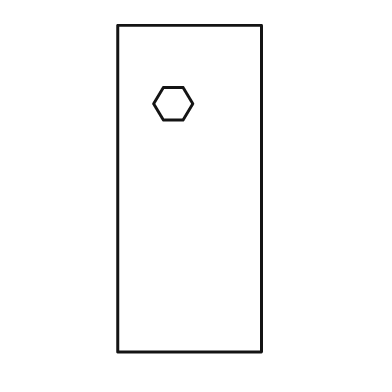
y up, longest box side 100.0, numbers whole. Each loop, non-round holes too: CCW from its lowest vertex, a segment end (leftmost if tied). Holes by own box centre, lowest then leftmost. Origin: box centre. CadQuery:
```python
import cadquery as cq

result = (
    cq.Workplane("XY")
    .moveTo(-22.0, -50.0)
    .lineTo(22.0, -50.0)
    .lineTo(22.0, 50.0)
    .lineTo(-22.0, 50.0)
    .close()
    .moveTo(-8.0, 21.0)
    .lineTo(-2.0, 21.0)
    .lineTo(1.0, 26.0)
    .lineTo(-2.0, 31.0)
    .lineTo(-8.0, 31.0)
    .lineTo(-11.0, 26.0)
    .close()
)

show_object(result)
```